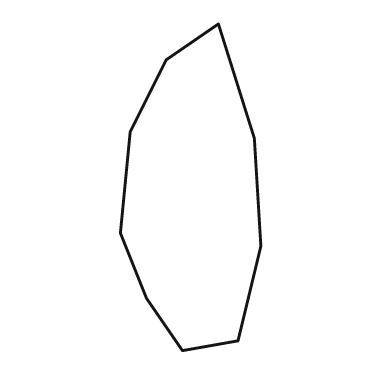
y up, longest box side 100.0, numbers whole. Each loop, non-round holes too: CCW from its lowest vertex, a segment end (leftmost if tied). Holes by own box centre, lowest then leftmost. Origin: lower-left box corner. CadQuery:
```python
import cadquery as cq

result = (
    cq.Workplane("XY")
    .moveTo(19.0, 0.0)
    .lineTo(36.0, 3.0)
    .lineTo(43.0, 32.0)
    .lineTo(41.0, 65.0)
    .lineTo(30.0, 100.0)
    .lineTo(14.0, 89.0)
    .lineTo(3.0, 67.0)
    .lineTo(0.0, 36.0)
    .lineTo(8.0, 16.0)
    .close()
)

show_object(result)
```